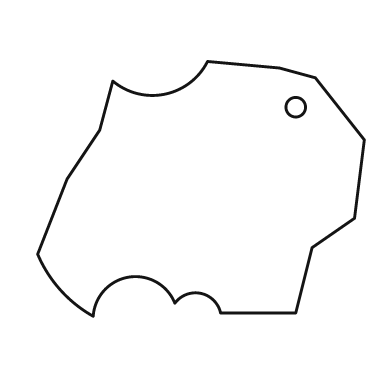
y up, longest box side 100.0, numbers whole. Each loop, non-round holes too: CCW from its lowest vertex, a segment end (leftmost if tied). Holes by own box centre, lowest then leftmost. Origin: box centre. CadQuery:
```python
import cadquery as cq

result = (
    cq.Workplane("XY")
    .moveTo(-33.0, -39.0)
    .threePointArc((-22.0, -27.0), (-8.0, -35.0))
    .threePointArc((0.0, -32.0), (6.0, -38.0))
    .lineTo(29.0, -38.0)
    .lineTo(34.0, -18.0)
    .lineTo(47.0, -9.0)
    .lineTo(50.0, 15.0)
    .lineTo(35.0, 34.0)
    .lineTo(24.0, 37.0)
    .lineTo(2.0, 39.0)
    .threePointArc((-11.0, 29.0), (-27.0, 33.0))
    .lineTo(-31.0, 18.0)
    .lineTo(-41.0, 3.0)
    .lineTo(-50.0, -20.0)
    .threePointArc((-43.0, -31.0), (-33.0, -39.0))
    .close()
    .moveTo(29.0, 25.0)
    .circle(3.0)
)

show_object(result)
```